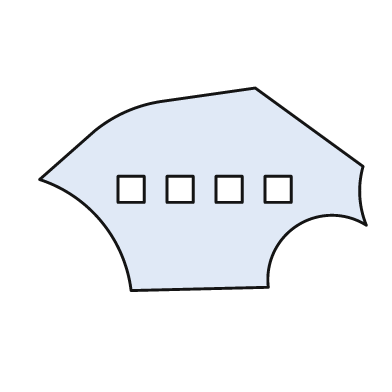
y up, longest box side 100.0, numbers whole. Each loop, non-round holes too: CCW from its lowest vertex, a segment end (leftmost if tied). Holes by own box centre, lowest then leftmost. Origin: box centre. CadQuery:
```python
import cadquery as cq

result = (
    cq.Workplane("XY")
    .moveTo(-22.0, -31.0)
    .lineTo(20.0, -30.0)
    .threePointArc((29.0, -11.0), (50.0, -11.0))
    .threePointArc((48.0, -2.0), (49.0, 7.0))
    .lineTo(16.0, 31.0)
    .lineTo(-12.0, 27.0)
    .threePointArc((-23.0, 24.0), (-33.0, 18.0))
    .lineTo(-50.0, 3.0)
    .threePointArc((-31.0, -10.0), (-22.0, -31.0))
    .close()
    .moveTo(-26.0, -4.0)
    .lineTo(-18.0, -4.0)
    .lineTo(-18.0, 4.0)
    .lineTo(-26.0, 4.0)
    .close()
    .moveTo(-11.0, -4.0)
    .lineTo(-3.0, -4.0)
    .lineTo(-3.0, 4.0)
    .lineTo(-11.0, 4.0)
    .close()
    .moveTo(4.0, -4.0)
    .lineTo(12.0, -4.0)
    .lineTo(12.0, 4.0)
    .lineTo(4.0, 4.0)
    .close()
    .moveTo(19.0, -4.0)
    .lineTo(27.0, -4.0)
    .lineTo(27.0, 4.0)
    .lineTo(19.0, 4.0)
    .close()
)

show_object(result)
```